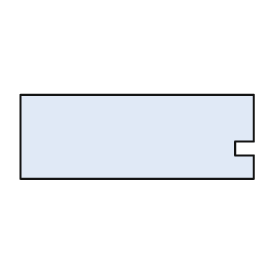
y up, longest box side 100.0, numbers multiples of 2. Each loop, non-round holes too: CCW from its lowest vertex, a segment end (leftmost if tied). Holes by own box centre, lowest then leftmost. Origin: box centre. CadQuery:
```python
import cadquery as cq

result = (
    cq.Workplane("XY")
    .moveTo(-50.0, -18.0)
    .lineTo(50.0, -18.0)
    .lineTo(50.0, -8.0)
    .lineTo(42.0, -8.0)
    .lineTo(42.0, -2.0)
    .lineTo(50.0, -2.0)
    .lineTo(50.0, 18.0)
    .lineTo(-50.0, 18.0)
    .close()
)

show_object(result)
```